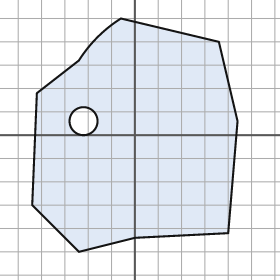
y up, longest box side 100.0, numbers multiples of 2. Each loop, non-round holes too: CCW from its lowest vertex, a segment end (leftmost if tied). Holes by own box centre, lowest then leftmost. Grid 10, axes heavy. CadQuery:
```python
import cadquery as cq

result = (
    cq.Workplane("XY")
    .moveTo(-24.0, -50.0)
    .lineTo(0.0, -44.0)
    .lineTo(40.0, -42.0)
    .lineTo(44.0, 6.0)
    .lineTo(36.0, 40.0)
    .lineTo(-6.0, 50.0)
    .threePointArc((-16.0, 42.0), (-24.0, 32.0))
    .lineTo(-42.0, 18.0)
    .lineTo(-44.0, -30.0)
    .close()
    .moveTo(-22.0, 6.0)
    .circle(6.0)
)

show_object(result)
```